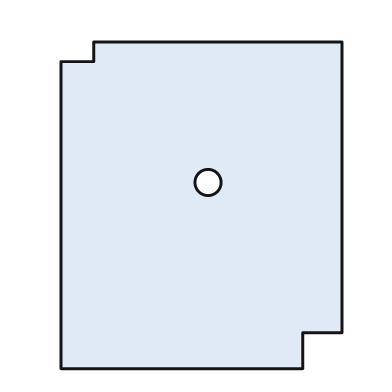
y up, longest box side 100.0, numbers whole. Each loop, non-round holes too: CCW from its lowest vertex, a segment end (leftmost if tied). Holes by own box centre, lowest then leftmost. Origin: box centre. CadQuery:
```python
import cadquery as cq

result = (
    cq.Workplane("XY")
    .moveTo(-43.0, -50.0)
    .lineTo(31.0, -50.0)
    .lineTo(31.0, -39.0)
    .lineTo(43.0, -39.0)
    .lineTo(43.0, 50.0)
    .lineTo(-33.0, 50.0)
    .lineTo(-33.0, 44.0)
    .lineTo(-43.0, 44.0)
    .close()
    .moveTo(2.0, 7.0)
    .circle(4.0)
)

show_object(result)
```